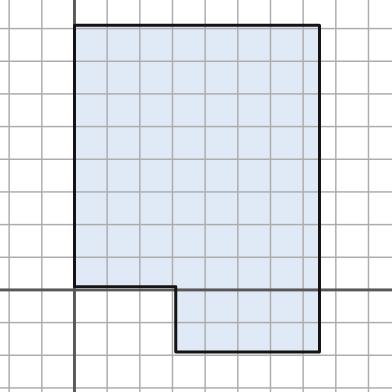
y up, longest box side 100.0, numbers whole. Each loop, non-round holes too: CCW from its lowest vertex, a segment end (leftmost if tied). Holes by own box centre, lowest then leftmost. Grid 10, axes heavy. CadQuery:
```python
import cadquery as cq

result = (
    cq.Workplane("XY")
    .moveTo(31.0, -19.0)
    .lineTo(75.0, -19.0)
    .lineTo(75.0, 81.0)
    .lineTo(0.0, 81.0)
    .lineTo(0.0, 1.0)
    .lineTo(31.0, 1.0)
    .close()
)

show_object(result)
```